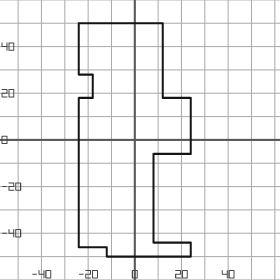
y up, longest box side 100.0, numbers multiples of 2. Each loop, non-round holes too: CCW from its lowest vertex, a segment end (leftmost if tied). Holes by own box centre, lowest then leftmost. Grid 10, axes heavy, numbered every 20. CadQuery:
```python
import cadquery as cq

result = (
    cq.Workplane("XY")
    .moveTo(-12.0, -50.0)
    .lineTo(24.0, -50.0)
    .lineTo(24.0, -44.0)
    .lineTo(8.0, -44.0)
    .lineTo(8.0, -6.0)
    .lineTo(24.0, -6.0)
    .lineTo(24.0, 18.0)
    .lineTo(12.0, 18.0)
    .lineTo(12.0, 50.0)
    .lineTo(-24.0, 50.0)
    .lineTo(-24.0, 28.0)
    .lineTo(-18.0, 28.0)
    .lineTo(-18.0, 18.0)
    .lineTo(-24.0, 18.0)
    .lineTo(-24.0, -46.0)
    .lineTo(-12.0, -46.0)
    .close()
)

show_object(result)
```